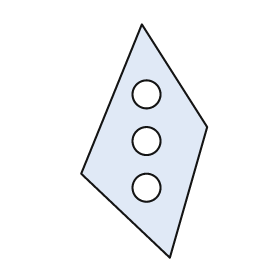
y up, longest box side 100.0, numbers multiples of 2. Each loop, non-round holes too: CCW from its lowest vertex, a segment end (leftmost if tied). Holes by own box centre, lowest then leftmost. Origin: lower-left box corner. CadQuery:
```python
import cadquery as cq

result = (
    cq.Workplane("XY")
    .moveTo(38.0, 0.0)
    .lineTo(54.0, 56.0)
    .lineTo(26.0, 100.0)
    .lineTo(0.0, 36.0)
    .close()
    .moveTo(28.0, 30.0)
    .circle(6.0)
    .moveTo(28.0, 50.0)
    .circle(6.0)
    .moveTo(28.0, 70.0)
    .circle(6.0)
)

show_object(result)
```